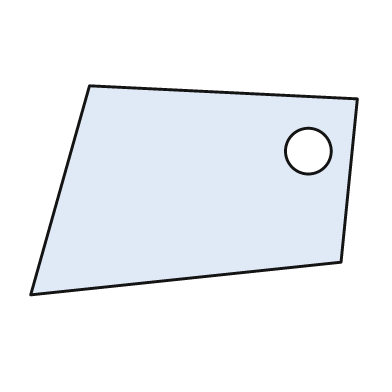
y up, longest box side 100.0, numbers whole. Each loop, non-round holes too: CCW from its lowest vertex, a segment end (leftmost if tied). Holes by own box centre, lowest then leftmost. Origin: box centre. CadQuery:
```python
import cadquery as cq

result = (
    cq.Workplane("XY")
    .moveTo(-50.0, -32.0)
    .lineTo(45.0, -22.0)
    .lineTo(50.0, 28.0)
    .lineTo(-32.0, 32.0)
    .close()
    .moveTo(35.0, 12.0)
    .circle(7.0)
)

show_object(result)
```